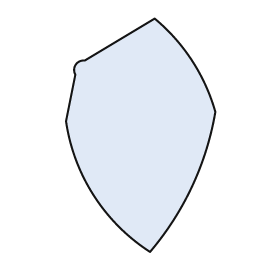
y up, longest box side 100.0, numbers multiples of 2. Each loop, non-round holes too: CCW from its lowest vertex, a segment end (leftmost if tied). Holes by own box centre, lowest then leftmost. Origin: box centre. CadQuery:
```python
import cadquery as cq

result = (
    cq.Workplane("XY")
    .moveTo(4.0, -50.0)
    .threePointArc((22.0, -22.0), (32.0, 10.0))
    .threePointArc((22.0, 32.0), (6.0, 50.0))
    .lineTo(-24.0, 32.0)
    .threePointArc((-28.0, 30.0), (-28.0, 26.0))
    .lineTo(-32.0, 6.0)
    .threePointArc((-20.0, -26.0), (4.0, -50.0))
    .close()
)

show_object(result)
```